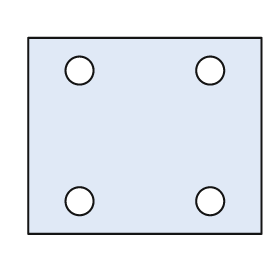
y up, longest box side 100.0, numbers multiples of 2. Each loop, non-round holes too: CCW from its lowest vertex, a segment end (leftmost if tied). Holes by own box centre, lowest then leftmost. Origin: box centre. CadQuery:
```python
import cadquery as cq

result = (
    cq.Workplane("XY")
    .moveTo(-50.0, -42.0)
    .lineTo(50.0, -42.0)
    .lineTo(50.0, 42.0)
    .lineTo(-50.0, 42.0)
    .close()
    .moveTo(-28.0, -28.0)
    .circle(6.0)
    .moveTo(28.0, -28.0)
    .circle(6.0)
    .moveTo(-28.0, 28.0)
    .circle(6.0)
    .moveTo(28.0, 28.0)
    .circle(6.0)
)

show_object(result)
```